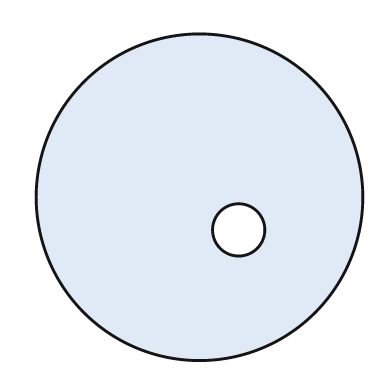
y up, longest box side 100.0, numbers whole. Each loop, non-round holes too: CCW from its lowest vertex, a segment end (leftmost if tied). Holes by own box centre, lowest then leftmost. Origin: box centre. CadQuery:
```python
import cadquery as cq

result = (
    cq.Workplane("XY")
    .moveTo(0.0, 0.0)
    .circle(50.0)
    .moveTo(12.0, -10.0)
    .circle(8.0)
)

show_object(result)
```